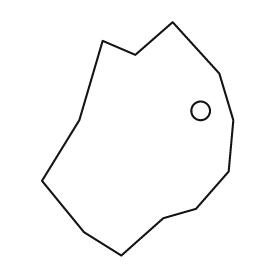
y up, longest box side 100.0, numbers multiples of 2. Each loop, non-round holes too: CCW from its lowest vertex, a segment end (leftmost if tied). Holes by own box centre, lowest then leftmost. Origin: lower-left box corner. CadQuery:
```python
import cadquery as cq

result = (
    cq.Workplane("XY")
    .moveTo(34.0, 0.0)
    .lineTo(52.0, 16.0)
    .lineTo(66.0, 20.0)
    .lineTo(80.0, 36.0)
    .lineTo(82.0, 58.0)
    .lineTo(76.0, 78.0)
    .lineTo(56.0, 100.0)
    .lineTo(40.0, 86.0)
    .lineTo(26.0, 92.0)
    .lineTo(16.0, 58.0)
    .lineTo(0.0, 32.0)
    .lineTo(18.0, 10.0)
    .close()
    .moveTo(68.0, 62.0)
    .circle(4.0)
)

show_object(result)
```